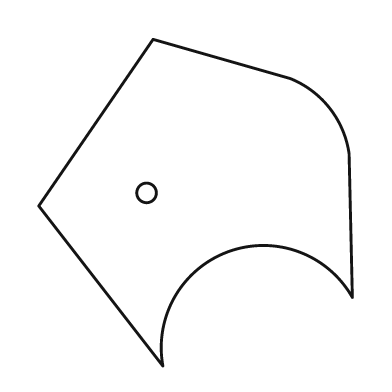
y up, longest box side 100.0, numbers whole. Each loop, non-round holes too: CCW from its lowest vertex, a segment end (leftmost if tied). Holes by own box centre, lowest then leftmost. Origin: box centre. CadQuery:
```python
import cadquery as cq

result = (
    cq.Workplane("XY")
    .moveTo(-10.0, -50.0)
    .threePointArc((10.0, -15.0), (48.0, -29.0))
    .lineTo(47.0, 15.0)
    .threePointArc((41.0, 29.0), (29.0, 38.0))
    .lineTo(-13.0, 50.0)
    .lineTo(-48.0, -1.0)
    .close()
    .moveTo(-15.0, 3.0)
    .circle(3.0)
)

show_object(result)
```